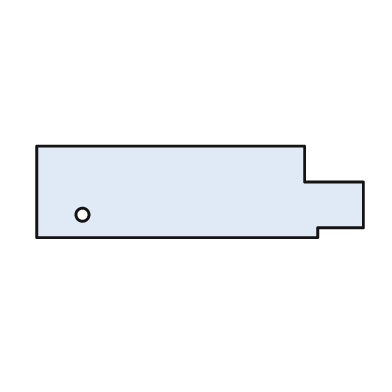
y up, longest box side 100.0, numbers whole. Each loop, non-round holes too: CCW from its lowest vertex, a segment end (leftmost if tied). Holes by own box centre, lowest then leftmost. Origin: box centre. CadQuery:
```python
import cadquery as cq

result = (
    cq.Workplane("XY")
    .moveTo(-50.0, -14.0)
    .lineTo(36.0, -14.0)
    .lineTo(36.0, -11.0)
    .lineTo(50.0, -11.0)
    .lineTo(50.0, 3.0)
    .lineTo(32.0, 3.0)
    .lineTo(32.0, 14.0)
    .lineTo(-50.0, 14.0)
    .close()
    .moveTo(-36.0, -7.0)
    .circle(2.0)
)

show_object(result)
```